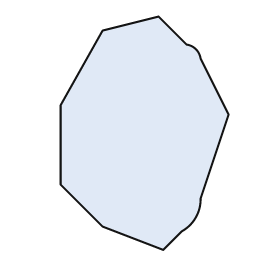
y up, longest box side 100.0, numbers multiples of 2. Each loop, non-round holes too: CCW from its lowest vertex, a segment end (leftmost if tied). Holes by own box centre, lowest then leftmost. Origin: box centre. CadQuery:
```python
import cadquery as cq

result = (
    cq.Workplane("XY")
    .moveTo(8.0, -50.0)
    .lineTo(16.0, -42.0)
    .threePointArc((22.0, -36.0), (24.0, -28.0))
    .lineTo(36.0, 8.0)
    .lineTo(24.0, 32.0)
    .threePointArc((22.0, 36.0), (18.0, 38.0))
    .lineTo(6.0, 50.0)
    .lineTo(-18.0, 44.0)
    .lineTo(-36.0, 12.0)
    .lineTo(-36.0, -22.0)
    .lineTo(-18.0, -40.0)
    .close()
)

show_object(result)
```